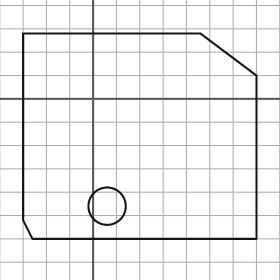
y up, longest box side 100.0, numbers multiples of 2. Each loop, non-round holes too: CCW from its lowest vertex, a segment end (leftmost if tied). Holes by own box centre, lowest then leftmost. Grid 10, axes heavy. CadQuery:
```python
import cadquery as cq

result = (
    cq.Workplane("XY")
    .moveTo(-26.0, -60.0)
    .lineTo(70.0, -60.0)
    .lineTo(70.0, 10.0)
    .lineTo(46.0, 28.0)
    .lineTo(-30.0, 28.0)
    .lineTo(-30.0, -52.0)
    .close()
    .moveTo(6.0, -46.0)
    .circle(8.0)
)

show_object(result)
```